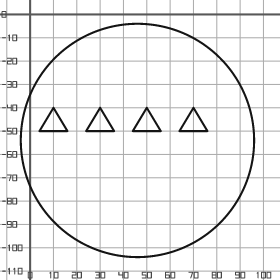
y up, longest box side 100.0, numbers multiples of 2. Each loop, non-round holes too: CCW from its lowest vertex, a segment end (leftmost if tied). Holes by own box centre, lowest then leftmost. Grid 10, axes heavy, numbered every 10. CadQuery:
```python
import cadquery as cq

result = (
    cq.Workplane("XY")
    .moveTo(46.0, -54.0)
    .circle(50.0)
    .moveTo(4.0, -50.0)
    .lineTo(16.0, -50.0)
    .lineTo(10.0, -40.0)
    .close()
    .moveTo(24.0, -50.0)
    .lineTo(36.0, -50.0)
    .lineTo(30.0, -40.0)
    .close()
    .moveTo(44.0, -50.0)
    .lineTo(56.0, -50.0)
    .lineTo(50.0, -40.0)
    .close()
    .moveTo(64.0, -50.0)
    .lineTo(76.0, -50.0)
    .lineTo(70.0, -40.0)
    .close()
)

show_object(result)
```